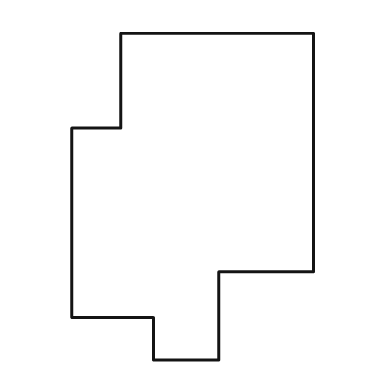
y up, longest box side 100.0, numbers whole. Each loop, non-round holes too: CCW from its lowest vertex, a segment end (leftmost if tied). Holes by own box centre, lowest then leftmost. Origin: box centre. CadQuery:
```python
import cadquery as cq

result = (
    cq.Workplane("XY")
    .moveTo(-12.0, -50.0)
    .lineTo(8.0, -50.0)
    .lineTo(8.0, -23.0)
    .lineTo(37.0, -23.0)
    .lineTo(37.0, 50.0)
    .lineTo(-22.0, 50.0)
    .lineTo(-22.0, 21.0)
    .lineTo(-37.0, 21.0)
    .lineTo(-37.0, -37.0)
    .lineTo(-12.0, -37.0)
    .close()
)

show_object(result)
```